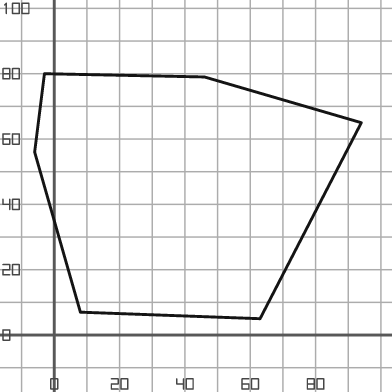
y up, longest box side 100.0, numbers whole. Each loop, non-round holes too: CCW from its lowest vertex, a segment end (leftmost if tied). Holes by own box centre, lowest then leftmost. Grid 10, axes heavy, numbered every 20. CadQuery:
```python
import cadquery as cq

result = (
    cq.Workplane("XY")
    .moveTo(63.0, 5.0)
    .lineTo(94.0, 65.0)
    .lineTo(46.0, 79.0)
    .lineTo(-3.0, 80.0)
    .lineTo(-6.0, 56.0)
    .lineTo(8.0, 7.0)
    .close()
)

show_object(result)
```